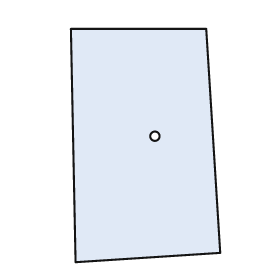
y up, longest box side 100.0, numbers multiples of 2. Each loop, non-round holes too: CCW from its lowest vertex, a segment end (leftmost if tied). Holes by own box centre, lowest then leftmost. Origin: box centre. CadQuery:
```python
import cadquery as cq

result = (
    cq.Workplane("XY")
    .moveTo(-30.0, -50.0)
    .lineTo(32.0, -46.0)
    .lineTo(26.0, 50.0)
    .lineTo(-32.0, 50.0)
    .close()
    .moveTo(4.0, 4.0)
    .circle(2.0)
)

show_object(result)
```